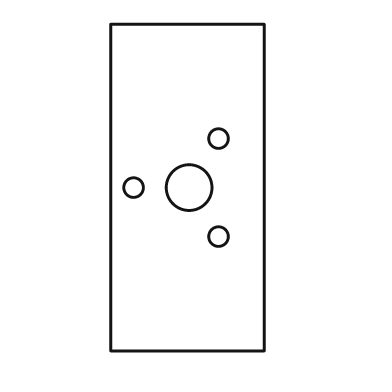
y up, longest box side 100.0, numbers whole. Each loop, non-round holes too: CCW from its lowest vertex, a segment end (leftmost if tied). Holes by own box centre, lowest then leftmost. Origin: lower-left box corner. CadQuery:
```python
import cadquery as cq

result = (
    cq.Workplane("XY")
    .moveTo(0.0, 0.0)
    .lineTo(47.0, 0.0)
    .lineTo(47.0, 100.0)
    .lineTo(0.0, 100.0)
    .close()
    .moveTo(33.0, 35.0)
    .circle(3.0)
    .moveTo(7.0, 50.0)
    .circle(3.0)
    .moveTo(24.0, 50.0)
    .circle(7.0)
    .moveTo(33.0, 65.0)
    .circle(3.0)
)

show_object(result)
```